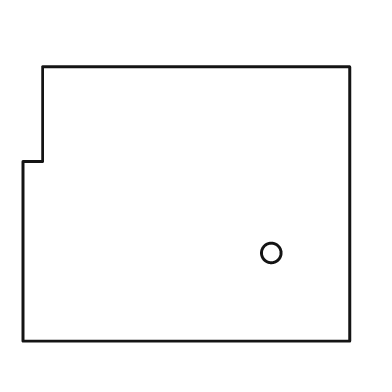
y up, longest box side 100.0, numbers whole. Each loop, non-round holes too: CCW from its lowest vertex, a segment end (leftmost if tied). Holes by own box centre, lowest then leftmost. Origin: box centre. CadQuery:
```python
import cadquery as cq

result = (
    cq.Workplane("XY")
    .moveTo(-50.0, -42.0)
    .lineTo(50.0, -42.0)
    .lineTo(50.0, 42.0)
    .lineTo(-44.0, 42.0)
    .lineTo(-44.0, 13.0)
    .lineTo(-50.0, 13.0)
    .close()
    .moveTo(26.0, -15.0)
    .circle(3.0)
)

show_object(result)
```